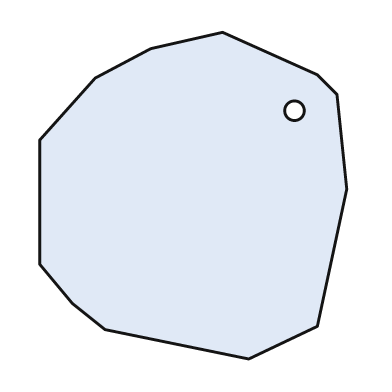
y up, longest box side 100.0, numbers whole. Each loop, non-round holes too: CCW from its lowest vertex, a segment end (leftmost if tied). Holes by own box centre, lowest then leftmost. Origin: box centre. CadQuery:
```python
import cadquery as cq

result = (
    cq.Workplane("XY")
    .moveTo(17.0, -50.0)
    .lineTo(38.0, -40.0)
    .lineTo(47.0, 2.0)
    .lineTo(44.0, 31.0)
    .lineTo(38.0, 37.0)
    .lineTo(9.0, 50.0)
    .lineTo(-13.0, 45.0)
    .lineTo(-30.0, 36.0)
    .lineTo(-47.0, 17.0)
    .lineTo(-47.0, -21.0)
    .lineTo(-37.0, -33.0)
    .lineTo(-27.0, -41.0)
    .close()
    .moveTo(31.0, 26.0)
    .circle(3.0)
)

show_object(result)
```